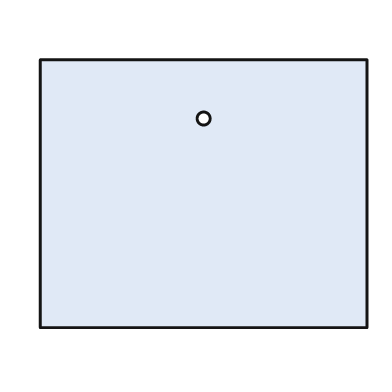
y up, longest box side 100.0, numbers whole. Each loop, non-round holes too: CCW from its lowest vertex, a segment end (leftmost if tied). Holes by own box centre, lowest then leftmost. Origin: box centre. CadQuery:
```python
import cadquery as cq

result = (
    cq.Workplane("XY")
    .moveTo(-50.0, -41.0)
    .lineTo(50.0, -41.0)
    .lineTo(50.0, 41.0)
    .lineTo(-50.0, 41.0)
    .close()
    .moveTo(0.0, 23.0)
    .circle(2.0)
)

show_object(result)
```